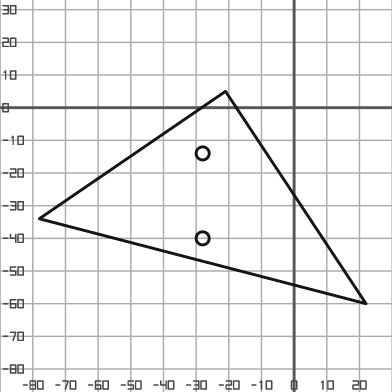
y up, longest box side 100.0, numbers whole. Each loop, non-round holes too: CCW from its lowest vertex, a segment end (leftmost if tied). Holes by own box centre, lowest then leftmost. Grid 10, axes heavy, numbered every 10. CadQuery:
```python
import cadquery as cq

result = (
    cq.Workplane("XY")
    .moveTo(22.0, -60.0)
    .lineTo(-21.0, 5.0)
    .lineTo(-78.0, -34.0)
    .close()
    .moveTo(-28.0, -40.0)
    .circle(2.0)
    .moveTo(-28.0, -14.0)
    .circle(2.0)
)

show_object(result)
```